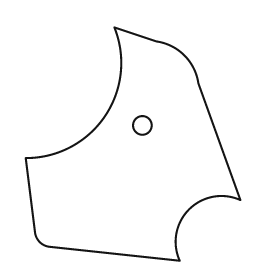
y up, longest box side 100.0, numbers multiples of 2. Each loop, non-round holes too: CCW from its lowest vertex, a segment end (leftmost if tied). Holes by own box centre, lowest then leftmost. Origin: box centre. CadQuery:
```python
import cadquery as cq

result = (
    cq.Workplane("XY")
    .moveTo(20.0, -50.0)
    .threePointArc((24.0, -28.0), (46.0, -24.0))
    .lineTo(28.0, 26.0)
    .threePointArc((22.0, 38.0), (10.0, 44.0))
    .lineTo(-8.0, 50.0)
    .threePointArc((-12.0, 12.0), (-46.0, -6.0))
    .lineTo(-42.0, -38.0)
    .threePointArc((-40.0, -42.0), (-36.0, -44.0))
    .close()
    .moveTo(4.0, 8.0)
    .circle(4.0)
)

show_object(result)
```